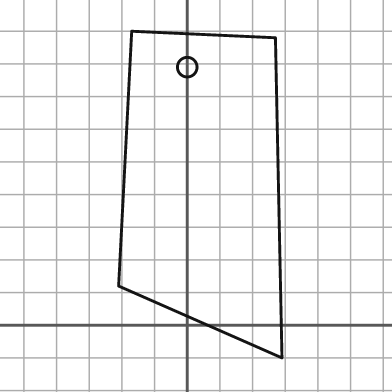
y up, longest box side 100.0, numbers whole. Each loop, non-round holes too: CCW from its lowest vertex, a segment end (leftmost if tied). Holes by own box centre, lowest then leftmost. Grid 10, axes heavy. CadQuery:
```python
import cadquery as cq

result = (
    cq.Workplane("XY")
    .moveTo(29.0, -10.0)
    .lineTo(27.0, 88.0)
    .lineTo(-17.0, 90.0)
    .lineTo(-21.0, 12.0)
    .close()
    .moveTo(0.0, 79.0)
    .circle(3.0)
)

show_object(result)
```